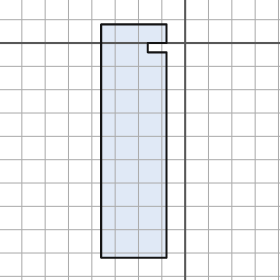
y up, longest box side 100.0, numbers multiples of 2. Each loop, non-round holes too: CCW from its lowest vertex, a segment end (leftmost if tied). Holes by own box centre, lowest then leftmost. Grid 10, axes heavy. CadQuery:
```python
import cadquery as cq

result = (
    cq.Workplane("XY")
    .moveTo(-36.0, -92.0)
    .lineTo(-8.0, -92.0)
    .lineTo(-8.0, -4.0)
    .lineTo(-16.0, -4.0)
    .lineTo(-16.0, 0.0)
    .lineTo(-8.0, 0.0)
    .lineTo(-8.0, 8.0)
    .lineTo(-36.0, 8.0)
    .close()
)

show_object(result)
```